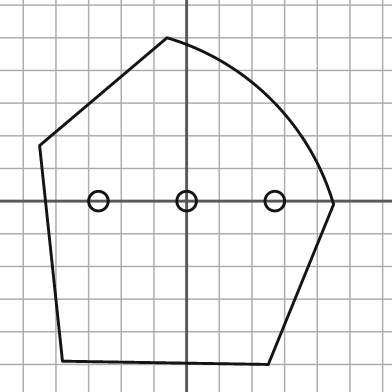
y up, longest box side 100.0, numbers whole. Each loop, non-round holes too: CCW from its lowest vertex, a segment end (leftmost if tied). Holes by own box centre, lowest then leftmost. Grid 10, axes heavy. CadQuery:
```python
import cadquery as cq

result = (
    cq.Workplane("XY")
    .moveTo(25.0, -50.0)
    .lineTo(45.0, -1.0)
    .threePointArc((26.0, 31.0), (-6.0, 50.0))
    .lineTo(-45.0, 17.0)
    .lineTo(-38.0, -49.0)
    .close()
    .moveTo(-27.0, 0.0)
    .circle(3.0)
    .moveTo(0.0, 0.0)
    .circle(3.0)
    .moveTo(27.0, 0.0)
    .circle(3.0)
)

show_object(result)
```